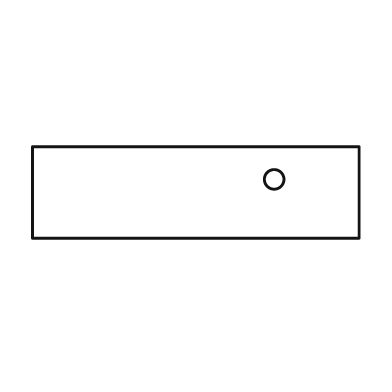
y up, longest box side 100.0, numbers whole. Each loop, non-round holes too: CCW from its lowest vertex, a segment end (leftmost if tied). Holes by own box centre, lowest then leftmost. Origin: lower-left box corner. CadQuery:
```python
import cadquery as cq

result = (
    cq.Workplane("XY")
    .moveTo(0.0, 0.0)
    .lineTo(100.0, 0.0)
    .lineTo(100.0, 28.0)
    .lineTo(0.0, 28.0)
    .close()
    .moveTo(74.0, 18.0)
    .circle(3.0)
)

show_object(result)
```